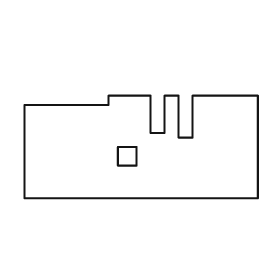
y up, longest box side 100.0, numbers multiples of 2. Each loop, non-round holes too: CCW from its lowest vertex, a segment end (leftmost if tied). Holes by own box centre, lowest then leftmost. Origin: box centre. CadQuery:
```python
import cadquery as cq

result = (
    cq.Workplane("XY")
    .moveTo(-50.0, -22.0)
    .lineTo(50.0, -22.0)
    .lineTo(50.0, 22.0)
    .lineTo(22.0, 22.0)
    .lineTo(22.0, 4.0)
    .lineTo(16.0, 4.0)
    .lineTo(16.0, 22.0)
    .lineTo(10.0, 22.0)
    .lineTo(10.0, 6.0)
    .lineTo(4.0, 6.0)
    .lineTo(4.0, 22.0)
    .lineTo(-14.0, 22.0)
    .lineTo(-14.0, 18.0)
    .lineTo(-50.0, 18.0)
    .close()
    .moveTo(-10.0, -8.0)
    .lineTo(-2.0, -8.0)
    .lineTo(-2.0, 0.0)
    .lineTo(-10.0, 0.0)
    .close()
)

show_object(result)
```